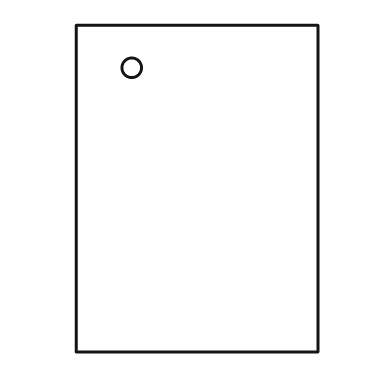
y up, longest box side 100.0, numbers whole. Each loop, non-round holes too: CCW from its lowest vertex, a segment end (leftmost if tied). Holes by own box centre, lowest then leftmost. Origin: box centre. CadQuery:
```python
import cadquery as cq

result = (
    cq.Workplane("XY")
    .moveTo(-37.0, -50.0)
    .lineTo(37.0, -50.0)
    .lineTo(37.0, 50.0)
    .lineTo(-37.0, 50.0)
    .close()
    .moveTo(-20.0, 37.0)
    .circle(3.0)
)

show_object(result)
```